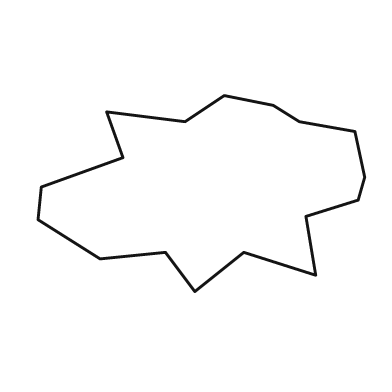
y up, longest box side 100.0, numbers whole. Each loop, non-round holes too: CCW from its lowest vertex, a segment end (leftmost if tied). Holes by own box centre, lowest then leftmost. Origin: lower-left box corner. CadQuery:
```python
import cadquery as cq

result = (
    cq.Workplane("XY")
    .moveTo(48.0, 0.0)
    .lineTo(63.0, 12.0)
    .lineTo(85.0, 5.0)
    .lineTo(82.0, 23.0)
    .lineTo(98.0, 28.0)
    .lineTo(100.0, 35.0)
    .lineTo(97.0, 49.0)
    .lineTo(80.0, 52.0)
    .lineTo(72.0, 57.0)
    .lineTo(57.0, 60.0)
    .lineTo(45.0, 52.0)
    .lineTo(21.0, 55.0)
    .lineTo(26.0, 41.0)
    .lineTo(1.0, 32.0)
    .lineTo(0.0, 22.0)
    .lineTo(19.0, 10.0)
    .lineTo(39.0, 12.0)
    .close()
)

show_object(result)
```